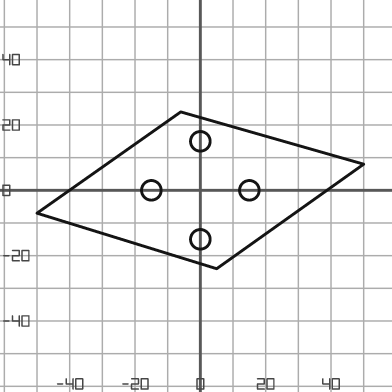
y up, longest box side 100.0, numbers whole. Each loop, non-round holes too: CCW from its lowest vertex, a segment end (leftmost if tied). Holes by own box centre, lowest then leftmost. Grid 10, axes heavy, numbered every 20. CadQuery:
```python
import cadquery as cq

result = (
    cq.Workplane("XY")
    .moveTo(5.0, -24.0)
    .lineTo(50.0, 8.0)
    .lineTo(-6.0, 24.0)
    .lineTo(-50.0, -7.0)
    .close()
    .moveTo(0.0, -15.0)
    .circle(3.0)
    .moveTo(-15.0, 0.0)
    .circle(3.0)
    .moveTo(15.0, 0.0)
    .circle(3.0)
    .moveTo(0.0, 15.0)
    .circle(3.0)
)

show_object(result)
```